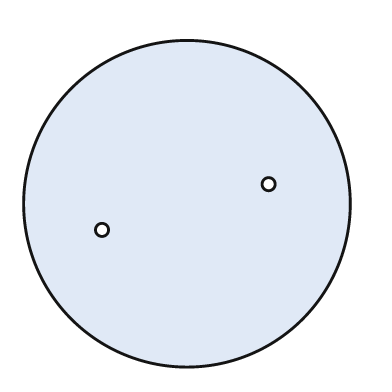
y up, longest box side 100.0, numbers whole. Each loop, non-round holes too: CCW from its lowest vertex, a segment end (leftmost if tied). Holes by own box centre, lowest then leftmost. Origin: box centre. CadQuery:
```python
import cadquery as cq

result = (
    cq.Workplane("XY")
    .moveTo(0.0, 0.0)
    .circle(50.0)
    .moveTo(-26.0, -8.0)
    .circle(2.0)
    .moveTo(25.0, 6.0)
    .circle(2.0)
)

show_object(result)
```